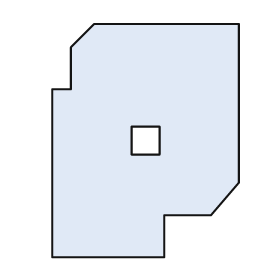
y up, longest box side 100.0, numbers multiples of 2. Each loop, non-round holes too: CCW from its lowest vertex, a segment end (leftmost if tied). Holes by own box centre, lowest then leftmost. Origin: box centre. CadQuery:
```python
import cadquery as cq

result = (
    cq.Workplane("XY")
    .moveTo(-40.0, -50.0)
    .lineTo(8.0, -50.0)
    .lineTo(8.0, -32.0)
    .lineTo(28.0, -32.0)
    .lineTo(40.0, -18.0)
    .lineTo(40.0, 50.0)
    .lineTo(-22.0, 50.0)
    .lineTo(-32.0, 40.0)
    .lineTo(-32.0, 22.0)
    .lineTo(-40.0, 22.0)
    .close()
    .moveTo(-6.0, -6.0)
    .lineTo(6.0, -6.0)
    .lineTo(6.0, 6.0)
    .lineTo(-6.0, 6.0)
    .close()
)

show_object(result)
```